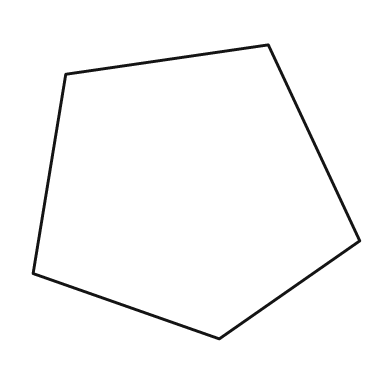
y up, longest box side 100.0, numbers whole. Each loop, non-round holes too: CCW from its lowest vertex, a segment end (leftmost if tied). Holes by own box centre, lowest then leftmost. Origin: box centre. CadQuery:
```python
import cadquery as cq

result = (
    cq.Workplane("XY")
    .moveTo(7.0, -45.0)
    .lineTo(50.0, -15.0)
    .lineTo(22.0, 45.0)
    .lineTo(-40.0, 36.0)
    .lineTo(-50.0, -25.0)
    .close()
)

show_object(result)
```